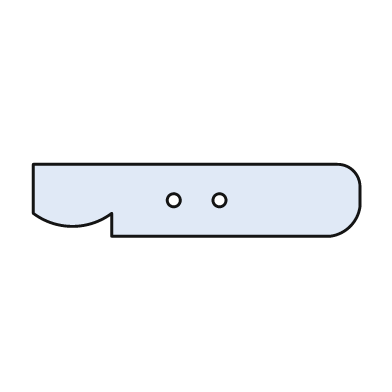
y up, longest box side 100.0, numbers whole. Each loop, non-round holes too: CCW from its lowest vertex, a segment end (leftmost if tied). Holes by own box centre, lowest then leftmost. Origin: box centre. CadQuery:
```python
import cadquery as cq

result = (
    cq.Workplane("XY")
    .moveTo(-26.0, -11.0)
    .lineTo(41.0, -11.0)
    .threePointArc((47.0, -8.0), (50.0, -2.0))
    .lineTo(50.0, 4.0)
    .threePointArc((48.0, 9.0), (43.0, 11.0))
    .lineTo(-50.0, 11.0)
    .lineTo(-50.0, -4.0)
    .threePointArc((-38.0, -8.0), (-26.0, -4.0))
    .close()
    .moveTo(-7.0, 0.0)
    .circle(2.0)
    .moveTo(7.0, 0.0)
    .circle(2.0)
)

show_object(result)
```